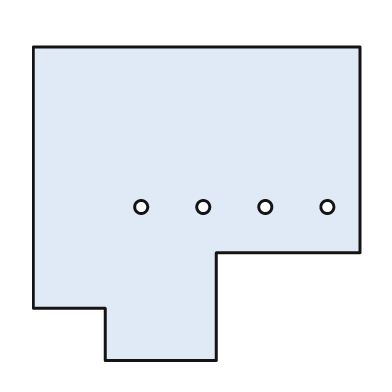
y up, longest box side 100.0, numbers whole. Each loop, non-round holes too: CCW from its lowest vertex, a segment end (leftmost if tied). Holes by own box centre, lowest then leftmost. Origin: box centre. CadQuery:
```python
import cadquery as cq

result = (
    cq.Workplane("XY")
    .moveTo(-28.0, -48.0)
    .lineTo(6.0, -48.0)
    .lineTo(6.0, -15.0)
    .lineTo(50.0, -15.0)
    .lineTo(50.0, 48.0)
    .lineTo(-50.0, 48.0)
    .lineTo(-50.0, -32.0)
    .lineTo(-28.0, -32.0)
    .close()
    .moveTo(-17.0, -1.0)
    .circle(2.0)
    .moveTo(2.0, -1.0)
    .circle(2.0)
    .moveTo(21.0, -1.0)
    .circle(2.0)
    .moveTo(40.0, -1.0)
    .circle(2.0)
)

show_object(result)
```